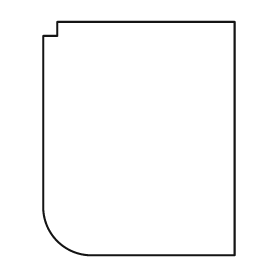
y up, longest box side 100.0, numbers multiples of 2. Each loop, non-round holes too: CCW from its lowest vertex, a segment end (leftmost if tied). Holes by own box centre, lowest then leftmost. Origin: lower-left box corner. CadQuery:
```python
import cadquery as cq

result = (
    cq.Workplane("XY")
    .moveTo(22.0, 0.0)
    .lineTo(82.0, 0.0)
    .lineTo(82.0, 100.0)
    .lineTo(6.0, 100.0)
    .lineTo(6.0, 94.0)
    .lineTo(0.0, 94.0)
    .lineTo(0.0, 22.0)
    .threePointArc((6.0, 6.0), (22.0, 0.0))
    .close()
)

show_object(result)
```